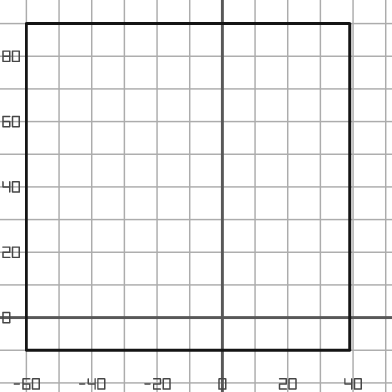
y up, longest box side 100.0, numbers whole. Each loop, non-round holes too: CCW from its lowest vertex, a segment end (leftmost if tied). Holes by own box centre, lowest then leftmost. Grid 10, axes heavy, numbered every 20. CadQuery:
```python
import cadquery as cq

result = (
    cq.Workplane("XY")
    .moveTo(-60.0, -10.0)
    .lineTo(39.0, -10.0)
    .lineTo(39.0, 90.0)
    .lineTo(-60.0, 90.0)
    .close()
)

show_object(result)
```